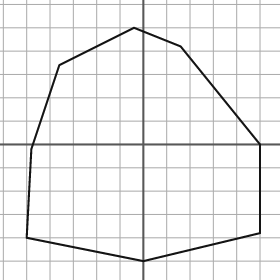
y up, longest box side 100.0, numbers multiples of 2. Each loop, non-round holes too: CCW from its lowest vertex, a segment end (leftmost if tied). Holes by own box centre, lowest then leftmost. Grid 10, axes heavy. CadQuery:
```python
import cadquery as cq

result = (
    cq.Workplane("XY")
    .moveTo(0.0, -50.0)
    .lineTo(50.0, -38.0)
    .lineTo(50.0, 0.0)
    .lineTo(16.0, 42.0)
    .lineTo(-4.0, 50.0)
    .lineTo(-36.0, 34.0)
    .lineTo(-48.0, -2.0)
    .lineTo(-50.0, -40.0)
    .close()
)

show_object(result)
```